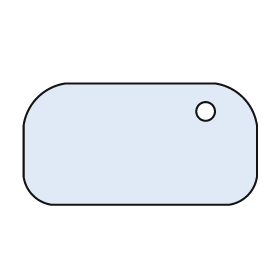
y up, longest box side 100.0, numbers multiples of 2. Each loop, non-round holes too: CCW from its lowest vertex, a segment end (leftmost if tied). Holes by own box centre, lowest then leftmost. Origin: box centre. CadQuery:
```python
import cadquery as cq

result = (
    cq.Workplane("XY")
    .moveTo(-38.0, -26.0)
    .lineTo(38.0, -26.0)
    .threePointArc((46.0, -22.0), (50.0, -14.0))
    .lineTo(50.0, 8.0)
    .threePointArc((44.0, 20.0), (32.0, 26.0))
    .lineTo(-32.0, 26.0)
    .threePointArc((-44.0, 20.0), (-50.0, 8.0))
    .lineTo(-50.0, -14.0)
    .threePointArc((-46.0, -22.0), (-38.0, -26.0))
    .close()
    .moveTo(28.0, 14.0)
    .circle(4.0)
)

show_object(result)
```